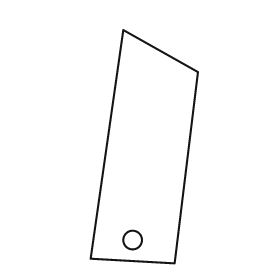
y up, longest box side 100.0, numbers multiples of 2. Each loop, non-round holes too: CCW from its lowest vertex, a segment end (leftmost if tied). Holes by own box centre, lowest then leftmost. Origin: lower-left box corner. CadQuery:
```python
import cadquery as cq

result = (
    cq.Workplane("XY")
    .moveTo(36.0, 0.0)
    .lineTo(46.0, 82.0)
    .lineTo(14.0, 100.0)
    .lineTo(0.0, 2.0)
    .close()
    .moveTo(18.0, 10.0)
    .circle(4.0)
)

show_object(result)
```